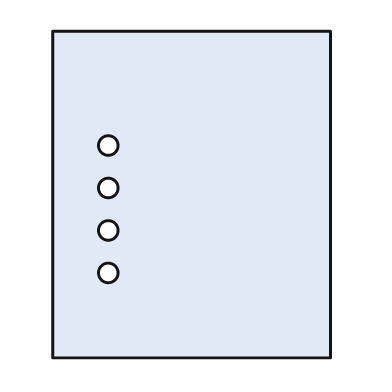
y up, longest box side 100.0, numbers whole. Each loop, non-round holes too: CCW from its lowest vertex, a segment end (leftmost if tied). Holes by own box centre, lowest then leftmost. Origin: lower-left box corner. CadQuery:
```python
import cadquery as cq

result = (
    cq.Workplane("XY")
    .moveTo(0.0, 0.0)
    .lineTo(85.0, 0.0)
    .lineTo(85.0, 100.0)
    .lineTo(0.0, 100.0)
    .close()
    .moveTo(17.0, 26.0)
    .circle(3.0)
    .moveTo(17.0, 39.0)
    .circle(3.0)
    .moveTo(17.0, 52.0)
    .circle(3.0)
    .moveTo(17.0, 65.0)
    .circle(3.0)
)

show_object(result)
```